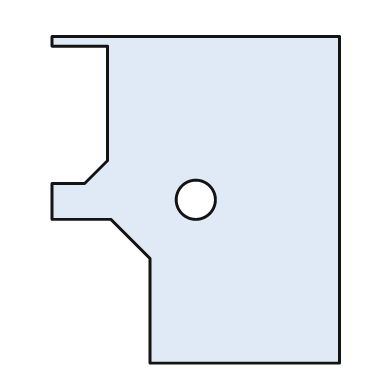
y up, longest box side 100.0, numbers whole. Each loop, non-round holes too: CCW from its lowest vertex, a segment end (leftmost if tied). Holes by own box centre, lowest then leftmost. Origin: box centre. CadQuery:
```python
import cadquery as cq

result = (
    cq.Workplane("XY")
    .moveTo(-14.0, -50.0)
    .lineTo(44.0, -50.0)
    .lineTo(44.0, 50.0)
    .lineTo(-44.0, 50.0)
    .lineTo(-44.0, 47.0)
    .lineTo(-27.0, 47.0)
    .lineTo(-27.0, 12.0)
    .lineTo(-34.0, 5.0)
    .lineTo(-44.0, 5.0)
    .lineTo(-44.0, -6.0)
    .lineTo(-26.0, -6.0)
    .lineTo(-14.0, -18.0)
    .close()
    .moveTo(0.0, 0.0)
    .circle(6.0)
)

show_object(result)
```